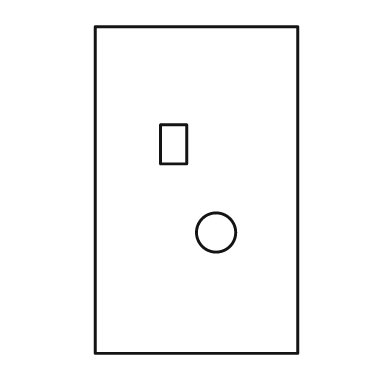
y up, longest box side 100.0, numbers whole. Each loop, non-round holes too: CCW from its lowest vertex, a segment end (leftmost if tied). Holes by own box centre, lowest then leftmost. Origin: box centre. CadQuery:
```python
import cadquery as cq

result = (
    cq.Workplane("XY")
    .moveTo(-31.0, -50.0)
    .lineTo(31.0, -50.0)
    .lineTo(31.0, 50.0)
    .lineTo(-31.0, 50.0)
    .close()
    .moveTo(6.0, -13.0)
    .circle(6.0)
    .moveTo(-11.0, 8.0)
    .lineTo(-3.0, 8.0)
    .lineTo(-3.0, 20.0)
    .lineTo(-11.0, 20.0)
    .close()
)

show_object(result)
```